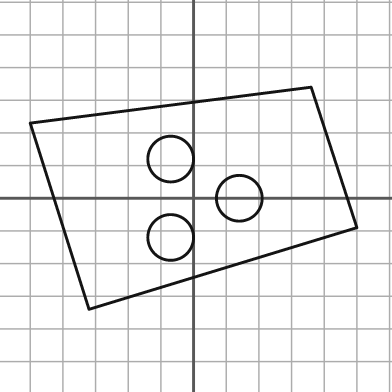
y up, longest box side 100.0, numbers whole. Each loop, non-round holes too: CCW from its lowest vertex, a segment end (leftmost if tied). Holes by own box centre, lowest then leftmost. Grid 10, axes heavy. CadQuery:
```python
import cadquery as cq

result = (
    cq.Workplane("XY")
    .moveTo(-32.0, -34.0)
    .lineTo(50.0, -9.0)
    .lineTo(36.0, 34.0)
    .lineTo(-50.0, 23.0)
    .close()
    .moveTo(-7.0, -12.0)
    .circle(7.0)
    .moveTo(14.0, 0.0)
    .circle(7.0)
    .moveTo(-7.0, 12.0)
    .circle(7.0)
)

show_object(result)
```